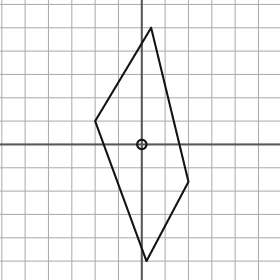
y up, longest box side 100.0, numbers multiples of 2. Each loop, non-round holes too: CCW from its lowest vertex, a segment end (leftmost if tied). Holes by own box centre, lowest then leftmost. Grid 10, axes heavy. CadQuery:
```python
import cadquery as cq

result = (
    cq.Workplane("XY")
    .moveTo(2.0, -50.0)
    .lineTo(20.0, -16.0)
    .lineTo(4.0, 50.0)
    .lineTo(-20.0, 10.0)
    .close()
    .moveTo(0.0, 0.0)
    .circle(2.0)
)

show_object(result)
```